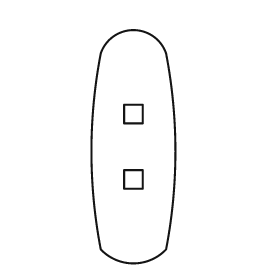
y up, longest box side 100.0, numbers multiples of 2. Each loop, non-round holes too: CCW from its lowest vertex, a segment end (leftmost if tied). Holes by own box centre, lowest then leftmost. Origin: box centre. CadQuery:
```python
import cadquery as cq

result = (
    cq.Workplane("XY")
    .moveTo(-14.0, -44.0)
    .threePointArc((0.0, -50.0), (14.0, -44.0))
    .threePointArc((18.0, -2.0), (14.0, 40.0))
    .threePointArc((0.0, 50.0), (-14.0, 40.0))
    .threePointArc((-18.0, -2.0), (-14.0, -44.0))
    .close()
    .moveTo(-4.0, -18.0)
    .lineTo(4.0, -18.0)
    .lineTo(4.0, -10.0)
    .lineTo(-4.0, -10.0)
    .close()
    .moveTo(-4.0, 10.0)
    .lineTo(4.0, 10.0)
    .lineTo(4.0, 18.0)
    .lineTo(-4.0, 18.0)
    .close()
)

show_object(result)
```